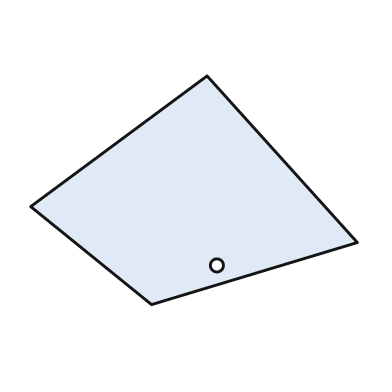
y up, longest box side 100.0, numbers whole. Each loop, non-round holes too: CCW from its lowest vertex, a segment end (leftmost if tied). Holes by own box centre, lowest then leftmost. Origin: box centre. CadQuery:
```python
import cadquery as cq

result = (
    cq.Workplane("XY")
    .moveTo(-13.0, -35.0)
    .lineTo(50.0, -16.0)
    .lineTo(4.0, 35.0)
    .lineTo(-50.0, -5.0)
    .close()
    .moveTo(7.0, -23.0)
    .circle(2.0)
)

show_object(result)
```